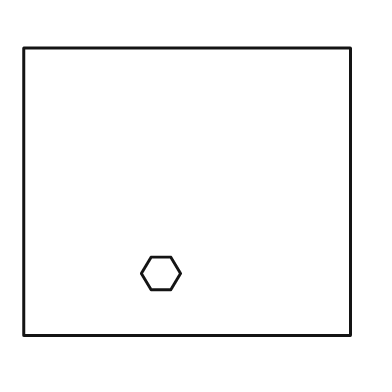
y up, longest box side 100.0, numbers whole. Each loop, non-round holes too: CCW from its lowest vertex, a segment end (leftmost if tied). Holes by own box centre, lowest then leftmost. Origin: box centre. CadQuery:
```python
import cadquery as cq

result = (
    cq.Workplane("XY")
    .moveTo(-50.0, -44.0)
    .lineTo(50.0, -44.0)
    .lineTo(50.0, 44.0)
    .lineTo(-50.0, 44.0)
    .close()
    .moveTo(-11.0, -30.0)
    .lineTo(-5.0, -30.0)
    .lineTo(-2.0, -25.0)
    .lineTo(-5.0, -20.0)
    .lineTo(-11.0, -20.0)
    .lineTo(-14.0, -25.0)
    .close()
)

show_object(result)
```